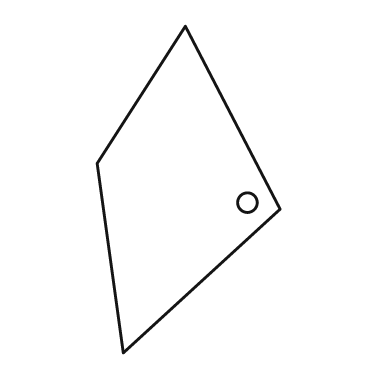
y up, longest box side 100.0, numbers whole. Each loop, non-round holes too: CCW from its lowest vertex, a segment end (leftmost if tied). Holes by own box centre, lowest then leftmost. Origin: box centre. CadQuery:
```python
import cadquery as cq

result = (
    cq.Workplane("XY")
    .moveTo(-20.0, -50.0)
    .lineTo(28.0, -6.0)
    .lineTo(-1.0, 50.0)
    .lineTo(-28.0, 8.0)
    .close()
    .moveTo(18.0, -4.0)
    .circle(3.0)
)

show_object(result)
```